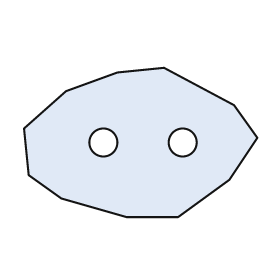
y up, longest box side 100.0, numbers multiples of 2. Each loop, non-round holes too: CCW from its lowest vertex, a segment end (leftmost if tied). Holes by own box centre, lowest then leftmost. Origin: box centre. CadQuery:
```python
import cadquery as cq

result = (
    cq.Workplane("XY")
    .moveTo(-6.0, -32.0)
    .lineTo(16.0, -32.0)
    .lineTo(38.0, -16.0)
    .lineTo(50.0, 2.0)
    .lineTo(40.0, 16.0)
    .lineTo(10.0, 32.0)
    .lineTo(-10.0, 30.0)
    .lineTo(-32.0, 22.0)
    .lineTo(-50.0, 6.0)
    .lineTo(-48.0, -14.0)
    .lineTo(-34.0, -24.0)
    .close()
    .moveTo(-16.0, 0.0)
    .circle(6.0)
    .moveTo(18.0, 0.0)
    .circle(6.0)
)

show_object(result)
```